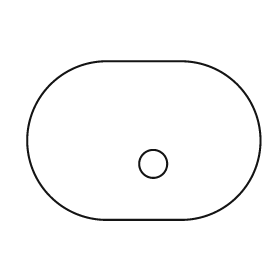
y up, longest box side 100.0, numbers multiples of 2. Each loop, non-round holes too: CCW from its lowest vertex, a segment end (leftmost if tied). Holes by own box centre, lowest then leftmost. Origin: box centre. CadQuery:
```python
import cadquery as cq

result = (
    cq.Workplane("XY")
    .moveTo(-16.0, -34.0)
    .lineTo(16.0, -34.0)
    .threePointArc((50.0, 0.0), (16.0, 34.0))
    .lineTo(-16.0, 34.0)
    .threePointArc((-50.0, 0.0), (-16.0, -34.0))
    .close()
    .moveTo(4.0, -10.0)
    .circle(6.0)
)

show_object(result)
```